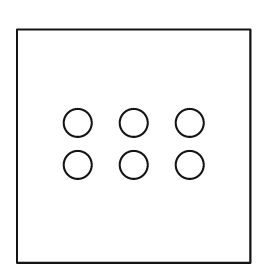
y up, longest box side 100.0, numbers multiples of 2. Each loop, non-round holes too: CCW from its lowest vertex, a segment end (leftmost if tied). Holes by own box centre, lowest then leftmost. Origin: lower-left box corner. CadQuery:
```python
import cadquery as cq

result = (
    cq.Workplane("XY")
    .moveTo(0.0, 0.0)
    .lineTo(100.0, 0.0)
    .lineTo(100.0, 100.0)
    .lineTo(0.0, 100.0)
    .close()
    .moveTo(26.0, 42.0)
    .circle(6.0)
    .moveTo(50.0, 42.0)
    .circle(6.0)
    .moveTo(74.0, 42.0)
    .circle(6.0)
    .moveTo(26.0, 60.0)
    .circle(6.0)
    .moveTo(50.0, 60.0)
    .circle(6.0)
    .moveTo(74.0, 60.0)
    .circle(6.0)
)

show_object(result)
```